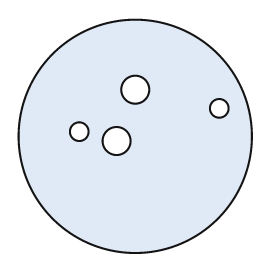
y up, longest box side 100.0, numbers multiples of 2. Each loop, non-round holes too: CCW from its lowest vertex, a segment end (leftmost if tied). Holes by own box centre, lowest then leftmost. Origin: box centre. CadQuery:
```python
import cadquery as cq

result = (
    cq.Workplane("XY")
    .moveTo(0.0, 0.0)
    .circle(50.0)
    .moveTo(-8.0, -2.0)
    .circle(6.0)
    .moveTo(-24.0, 2.0)
    .circle(4.0)
    .moveTo(36.0, 12.0)
    .circle(4.0)
    .moveTo(0.0, 20.0)
    .circle(6.0)
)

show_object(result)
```